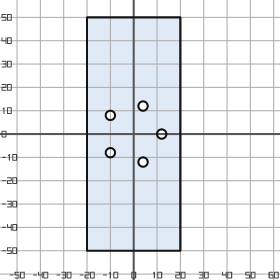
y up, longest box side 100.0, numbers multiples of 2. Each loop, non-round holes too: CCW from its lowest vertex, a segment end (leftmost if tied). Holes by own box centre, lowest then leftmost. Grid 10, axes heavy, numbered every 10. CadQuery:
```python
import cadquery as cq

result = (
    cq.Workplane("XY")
    .moveTo(-20.0, -50.0)
    .lineTo(20.0, -50.0)
    .lineTo(20.0, 50.0)
    .lineTo(-20.0, 50.0)
    .close()
    .moveTo(4.0, -12.0)
    .circle(2.0)
    .moveTo(-10.0, -8.0)
    .circle(2.0)
    .moveTo(12.0, 0.0)
    .circle(2.0)
    .moveTo(-10.0, 8.0)
    .circle(2.0)
    .moveTo(4.0, 12.0)
    .circle(2.0)
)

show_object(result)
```